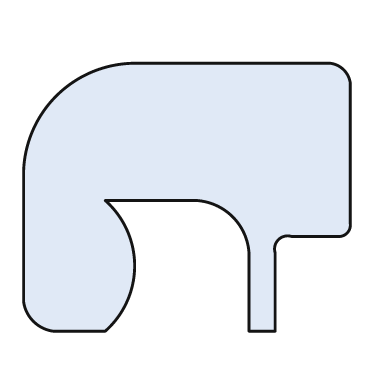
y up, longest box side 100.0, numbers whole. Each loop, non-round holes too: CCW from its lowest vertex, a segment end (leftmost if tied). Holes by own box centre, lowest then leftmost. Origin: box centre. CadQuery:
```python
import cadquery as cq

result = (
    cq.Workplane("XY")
    .moveTo(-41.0, -41.0)
    .lineTo(-25.0, -41.0)
    .threePointArc((-16.0, -21.0), (-25.0, -1.0))
    .lineTo(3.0, -1.0)
    .threePointArc((14.0, -6.0), (19.0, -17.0))
    .lineTo(19.0, -41.0)
    .lineTo(27.0, -41.0)
    .lineTo(27.0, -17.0)
    .threePointArc((28.0, -13.0), (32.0, -12.0))
    .lineTo(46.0, -12.0)
    .threePointArc((49.0, -11.0), (50.0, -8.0))
    .lineTo(50.0, 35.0)
    .threePointArc((48.0, 39.0), (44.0, 41.0))
    .lineTo(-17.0, 41.0)
    .threePointArc((-40.0, 31.0), (-50.0, 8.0))
    .lineTo(-50.0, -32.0)
    .threePointArc((-47.0, -38.0), (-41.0, -41.0))
    .close()
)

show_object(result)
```